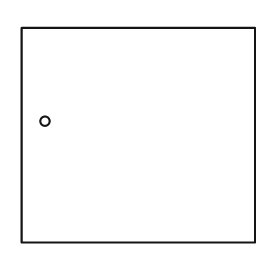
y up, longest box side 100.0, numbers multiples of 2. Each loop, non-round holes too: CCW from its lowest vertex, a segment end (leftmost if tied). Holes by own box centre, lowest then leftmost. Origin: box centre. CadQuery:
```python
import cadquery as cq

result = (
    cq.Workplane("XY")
    .moveTo(-50.0, -46.0)
    .lineTo(50.0, -46.0)
    .lineTo(50.0, 46.0)
    .lineTo(-50.0, 46.0)
    .close()
    .moveTo(-40.0, 6.0)
    .circle(2.0)
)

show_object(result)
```